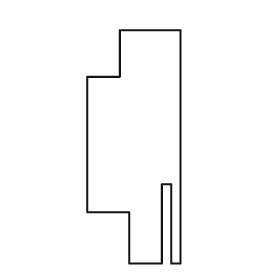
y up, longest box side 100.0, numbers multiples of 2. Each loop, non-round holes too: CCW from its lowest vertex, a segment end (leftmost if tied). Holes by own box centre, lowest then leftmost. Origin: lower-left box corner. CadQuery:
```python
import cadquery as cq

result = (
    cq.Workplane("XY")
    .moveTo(18.0, 0.0)
    .lineTo(32.0, 0.0)
    .lineTo(32.0, 34.0)
    .lineTo(36.0, 34.0)
    .lineTo(36.0, 0.0)
    .lineTo(40.0, 0.0)
    .lineTo(40.0, 100.0)
    .lineTo(14.0, 100.0)
    .lineTo(14.0, 80.0)
    .lineTo(0.0, 80.0)
    .lineTo(0.0, 22.0)
    .lineTo(18.0, 22.0)
    .close()
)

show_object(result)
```